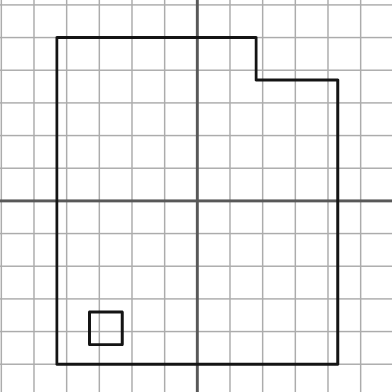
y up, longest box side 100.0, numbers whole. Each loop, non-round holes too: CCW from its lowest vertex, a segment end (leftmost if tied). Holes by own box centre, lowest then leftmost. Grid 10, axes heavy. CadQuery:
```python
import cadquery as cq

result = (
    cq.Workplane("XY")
    .moveTo(-43.0, -50.0)
    .lineTo(43.0, -50.0)
    .lineTo(43.0, 37.0)
    .lineTo(18.0, 37.0)
    .lineTo(18.0, 50.0)
    .lineTo(-43.0, 50.0)
    .close()
    .moveTo(-33.0, -44.0)
    .lineTo(-23.0, -44.0)
    .lineTo(-23.0, -34.0)
    .lineTo(-33.0, -34.0)
    .close()
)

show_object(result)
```